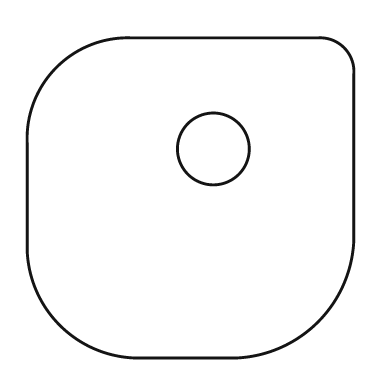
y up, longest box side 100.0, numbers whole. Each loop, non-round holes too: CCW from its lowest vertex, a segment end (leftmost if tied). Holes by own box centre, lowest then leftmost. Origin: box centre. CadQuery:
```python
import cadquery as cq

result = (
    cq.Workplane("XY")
    .moveTo(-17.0, -49.0)
    .lineTo(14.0, -49.0)
    .threePointArc((39.0, -38.0), (50.0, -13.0))
    .lineTo(50.0, 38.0)
    .threePointArc((47.0, 46.0), (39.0, 49.0))
    .lineTo(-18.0, 49.0)
    .threePointArc((-41.0, 40.0), (-50.0, 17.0))
    .lineTo(-50.0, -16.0)
    .threePointArc((-40.0, -39.0), (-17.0, -49.0))
    .close()
    .moveTo(7.0, 15.0)
    .circle(11.0)
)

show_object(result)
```